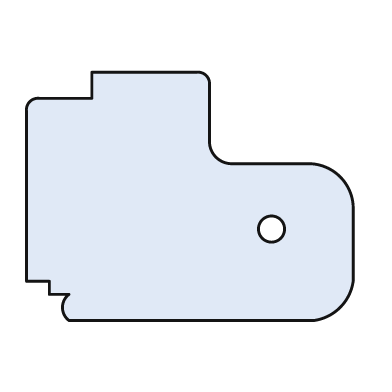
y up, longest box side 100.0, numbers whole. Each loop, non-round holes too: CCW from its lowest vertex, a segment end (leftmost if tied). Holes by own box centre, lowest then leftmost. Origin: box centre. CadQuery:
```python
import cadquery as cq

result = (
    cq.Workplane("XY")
    .moveTo(-37.0, -38.0)
    .lineTo(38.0, -38.0)
    .threePointArc((46.0, -34.0), (50.0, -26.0))
    .lineTo(50.0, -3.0)
    .threePointArc((46.0, 6.0), (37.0, 10.0))
    .lineTo(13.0, 10.0)
    .threePointArc((8.0, 12.0), (6.0, 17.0))
    .lineTo(6.0, 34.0)
    .threePointArc((5.0, 37.0), (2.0, 38.0))
    .lineTo(-30.0, 38.0)
    .lineTo(-30.0, 30.0)
    .lineTo(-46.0, 30.0)
    .threePointArc((-49.0, 29.0), (-50.0, 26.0))
    .lineTo(-50.0, -26.0)
    .lineTo(-43.0, -26.0)
    .lineTo(-43.0, -30.0)
    .lineTo(-37.0, -30.0)
    .threePointArc((-39.0, -34.0), (-37.0, -38.0))
    .close()
    .moveTo(25.0, -10.0)
    .circle(4.0)
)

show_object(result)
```